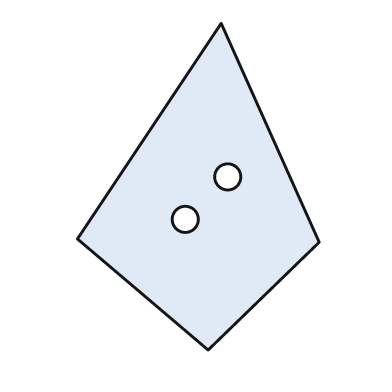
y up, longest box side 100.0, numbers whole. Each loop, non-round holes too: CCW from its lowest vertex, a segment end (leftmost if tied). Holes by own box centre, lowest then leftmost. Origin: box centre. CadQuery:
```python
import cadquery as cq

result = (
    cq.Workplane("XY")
    .moveTo(3.0, -50.0)
    .lineTo(37.0, -17.0)
    .lineTo(7.0, 50.0)
    .lineTo(-37.0, -16.0)
    .close()
    .moveTo(-4.0, -10.0)
    .circle(4.0)
    .moveTo(9.0, 3.0)
    .circle(4.0)
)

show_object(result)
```